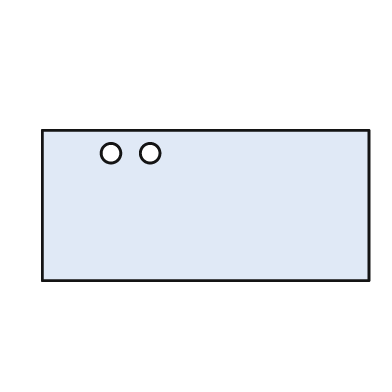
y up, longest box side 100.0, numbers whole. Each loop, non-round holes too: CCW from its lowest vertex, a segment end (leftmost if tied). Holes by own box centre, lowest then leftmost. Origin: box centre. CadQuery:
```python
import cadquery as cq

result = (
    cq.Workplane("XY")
    .moveTo(-50.0, -23.0)
    .lineTo(50.0, -23.0)
    .lineTo(50.0, 23.0)
    .lineTo(-50.0, 23.0)
    .close()
    .moveTo(-29.0, 16.0)
    .circle(3.0)
    .moveTo(-17.0, 16.0)
    .circle(3.0)
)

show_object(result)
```